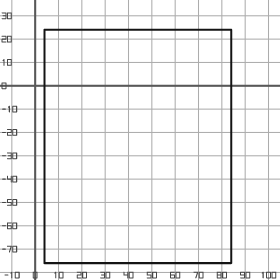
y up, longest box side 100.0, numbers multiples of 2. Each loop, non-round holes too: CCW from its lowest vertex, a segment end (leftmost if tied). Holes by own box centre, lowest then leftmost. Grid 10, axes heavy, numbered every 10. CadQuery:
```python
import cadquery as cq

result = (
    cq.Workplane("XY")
    .moveTo(4.0, -76.0)
    .lineTo(84.0, -76.0)
    .lineTo(84.0, 24.0)
    .lineTo(4.0, 24.0)
    .close()
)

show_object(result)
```